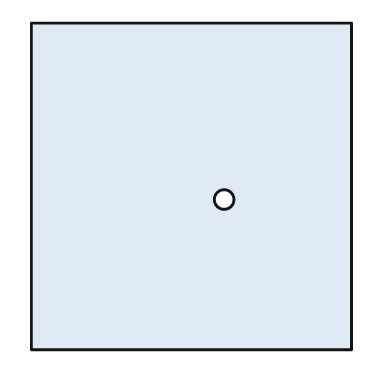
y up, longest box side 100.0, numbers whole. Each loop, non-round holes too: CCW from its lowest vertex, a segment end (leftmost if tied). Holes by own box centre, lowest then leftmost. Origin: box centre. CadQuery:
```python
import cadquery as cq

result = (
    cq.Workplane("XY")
    .moveTo(-49.0, -50.0)
    .lineTo(49.0, -50.0)
    .lineTo(49.0, 50.0)
    .lineTo(-49.0, 50.0)
    .close()
    .moveTo(10.0, -4.0)
    .circle(3.0)
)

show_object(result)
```